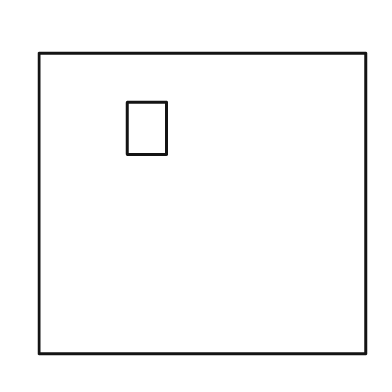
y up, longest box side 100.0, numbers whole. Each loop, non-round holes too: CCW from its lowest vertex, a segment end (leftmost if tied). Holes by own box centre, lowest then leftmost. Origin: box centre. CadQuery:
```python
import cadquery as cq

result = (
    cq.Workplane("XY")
    .moveTo(-50.0, -46.0)
    .lineTo(50.0, -46.0)
    .lineTo(50.0, 46.0)
    .lineTo(-50.0, 46.0)
    .close()
    .moveTo(-23.0, 15.0)
    .lineTo(-11.0, 15.0)
    .lineTo(-11.0, 31.0)
    .lineTo(-23.0, 31.0)
    .close()
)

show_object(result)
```